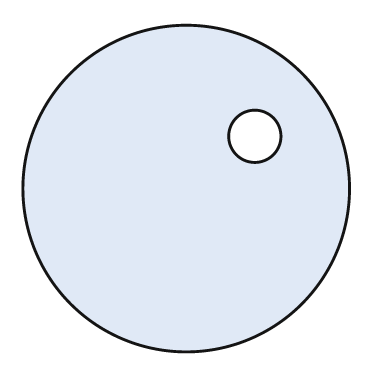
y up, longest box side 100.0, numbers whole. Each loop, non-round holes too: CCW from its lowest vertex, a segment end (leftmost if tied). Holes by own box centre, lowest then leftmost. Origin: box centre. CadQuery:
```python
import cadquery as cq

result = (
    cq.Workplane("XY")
    .moveTo(0.0, 0.0)
    .circle(50.0)
    .moveTo(21.0, 16.0)
    .circle(8.0)
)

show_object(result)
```